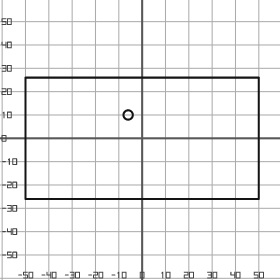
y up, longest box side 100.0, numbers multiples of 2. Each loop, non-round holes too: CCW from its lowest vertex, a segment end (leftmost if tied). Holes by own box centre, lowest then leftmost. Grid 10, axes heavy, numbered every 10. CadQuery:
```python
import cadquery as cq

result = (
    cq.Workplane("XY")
    .moveTo(-50.0, -26.0)
    .lineTo(50.0, -26.0)
    .lineTo(50.0, 26.0)
    .lineTo(-50.0, 26.0)
    .close()
    .moveTo(-6.0, 10.0)
    .circle(2.0)
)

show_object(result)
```